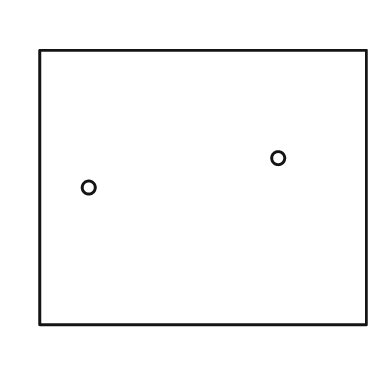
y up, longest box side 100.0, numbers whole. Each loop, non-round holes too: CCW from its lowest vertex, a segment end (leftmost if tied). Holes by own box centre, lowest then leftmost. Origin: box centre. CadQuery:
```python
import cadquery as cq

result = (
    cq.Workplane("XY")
    .moveTo(-50.0, -42.0)
    .lineTo(50.0, -42.0)
    .lineTo(50.0, 42.0)
    .lineTo(-50.0, 42.0)
    .close()
    .moveTo(-35.0, 0.0)
    .circle(2.0)
    .moveTo(23.0, 9.0)
    .circle(2.0)
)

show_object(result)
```